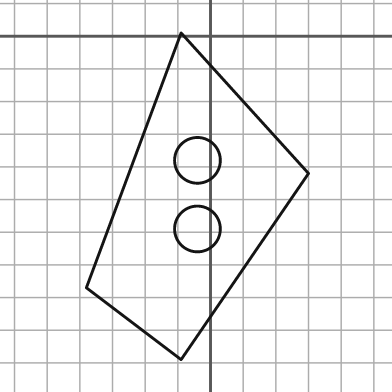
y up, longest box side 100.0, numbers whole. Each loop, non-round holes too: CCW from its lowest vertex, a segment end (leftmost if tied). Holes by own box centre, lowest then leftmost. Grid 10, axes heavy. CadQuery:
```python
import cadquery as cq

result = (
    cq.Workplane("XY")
    .moveTo(-9.0, -99.0)
    .lineTo(30.0, -42.0)
    .lineTo(-9.0, 1.0)
    .lineTo(-38.0, -77.0)
    .close()
    .moveTo(-4.0, -59.0)
    .circle(7.0)
    .moveTo(-4.0, -38.0)
    .circle(7.0)
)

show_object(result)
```